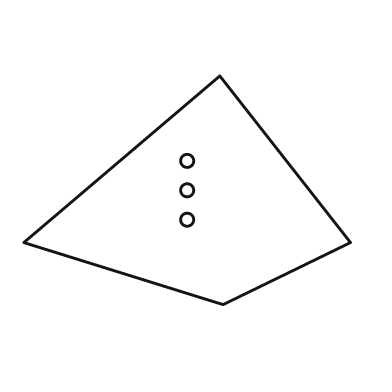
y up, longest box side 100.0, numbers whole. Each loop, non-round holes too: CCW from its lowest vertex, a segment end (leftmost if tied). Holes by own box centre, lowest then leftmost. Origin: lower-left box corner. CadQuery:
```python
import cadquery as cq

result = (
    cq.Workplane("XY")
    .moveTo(61.0, 0.0)
    .lineTo(100.0, 19.0)
    .lineTo(60.0, 70.0)
    .lineTo(0.0, 19.0)
    .close()
    .moveTo(50.0, 26.0)
    .circle(2.0)
    .moveTo(50.0, 35.0)
    .circle(2.0)
    .moveTo(50.0, 44.0)
    .circle(2.0)
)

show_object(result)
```